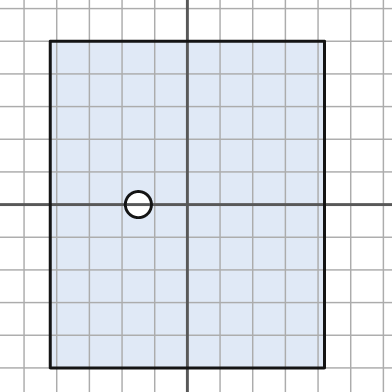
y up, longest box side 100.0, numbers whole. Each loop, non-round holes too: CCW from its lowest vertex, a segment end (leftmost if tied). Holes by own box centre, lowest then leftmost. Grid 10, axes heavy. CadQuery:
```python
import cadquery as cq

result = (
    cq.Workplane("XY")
    .moveTo(-42.0, -50.0)
    .lineTo(42.0, -50.0)
    .lineTo(42.0, 50.0)
    .lineTo(-42.0, 50.0)
    .close()
    .moveTo(-15.0, 0.0)
    .circle(4.0)
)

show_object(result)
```